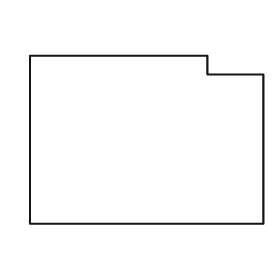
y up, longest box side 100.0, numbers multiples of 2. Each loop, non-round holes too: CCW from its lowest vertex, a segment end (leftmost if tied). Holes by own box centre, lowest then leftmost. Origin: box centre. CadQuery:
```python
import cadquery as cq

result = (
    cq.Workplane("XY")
    .moveTo(-50.0, -36.0)
    .lineTo(50.0, -36.0)
    .lineTo(50.0, 28.0)
    .lineTo(26.0, 28.0)
    .lineTo(26.0, 36.0)
    .lineTo(-50.0, 36.0)
    .close()
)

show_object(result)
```